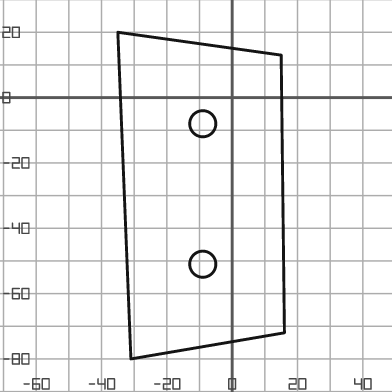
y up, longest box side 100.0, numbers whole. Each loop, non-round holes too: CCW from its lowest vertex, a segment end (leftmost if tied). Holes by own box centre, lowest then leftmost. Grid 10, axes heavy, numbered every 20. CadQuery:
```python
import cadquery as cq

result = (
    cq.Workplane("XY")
    .moveTo(-31.0, -80.0)
    .lineTo(16.0, -72.0)
    .lineTo(15.0, 13.0)
    .lineTo(-35.0, 20.0)
    .close()
    .moveTo(-9.0, -51.0)
    .circle(4.0)
    .moveTo(-9.0, -8.0)
    .circle(4.0)
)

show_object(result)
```